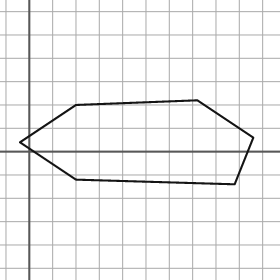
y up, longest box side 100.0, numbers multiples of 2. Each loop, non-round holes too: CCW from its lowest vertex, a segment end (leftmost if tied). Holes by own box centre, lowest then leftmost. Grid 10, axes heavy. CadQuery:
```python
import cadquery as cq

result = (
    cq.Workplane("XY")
    .moveTo(88.0, -14.0)
    .lineTo(96.0, 6.0)
    .lineTo(72.0, 22.0)
    .lineTo(20.0, 20.0)
    .lineTo(-4.0, 4.0)
    .lineTo(20.0, -12.0)
    .close()
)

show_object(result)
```